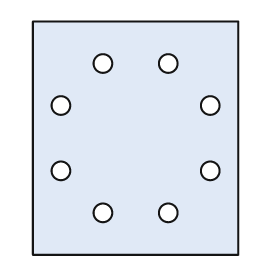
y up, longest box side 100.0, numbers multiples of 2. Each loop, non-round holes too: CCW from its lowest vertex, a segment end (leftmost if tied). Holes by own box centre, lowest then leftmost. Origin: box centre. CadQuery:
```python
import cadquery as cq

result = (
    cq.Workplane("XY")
    .moveTo(-44.0, -50.0)
    .lineTo(44.0, -50.0)
    .lineTo(44.0, 50.0)
    .lineTo(-44.0, 50.0)
    .close()
    .moveTo(-14.0, -32.0)
    .circle(4.0)
    .moveTo(14.0, -32.0)
    .circle(4.0)
    .moveTo(-32.0, -14.0)
    .circle(4.0)
    .moveTo(32.0, -14.0)
    .circle(4.0)
    .moveTo(-32.0, 14.0)
    .circle(4.0)
    .moveTo(32.0, 14.0)
    .circle(4.0)
    .moveTo(-14.0, 32.0)
    .circle(4.0)
    .moveTo(14.0, 32.0)
    .circle(4.0)
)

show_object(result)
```